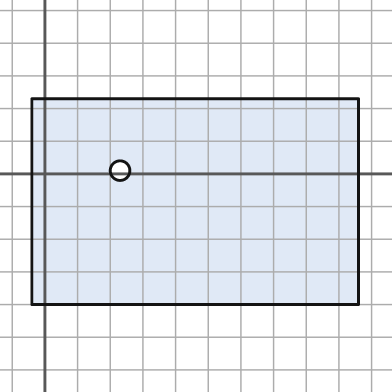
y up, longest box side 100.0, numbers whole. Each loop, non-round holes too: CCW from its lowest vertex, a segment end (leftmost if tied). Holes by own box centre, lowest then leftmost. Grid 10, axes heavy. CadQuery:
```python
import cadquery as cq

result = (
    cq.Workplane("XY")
    .moveTo(-4.0, -40.0)
    .lineTo(96.0, -40.0)
    .lineTo(96.0, 23.0)
    .lineTo(-4.0, 23.0)
    .close()
    .moveTo(23.0, 1.0)
    .circle(3.0)
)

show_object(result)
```